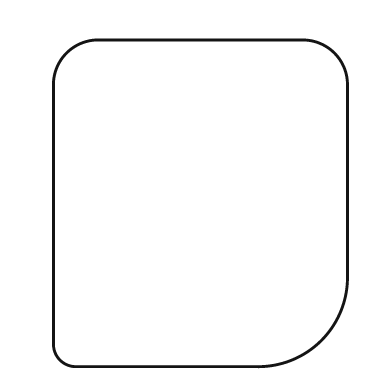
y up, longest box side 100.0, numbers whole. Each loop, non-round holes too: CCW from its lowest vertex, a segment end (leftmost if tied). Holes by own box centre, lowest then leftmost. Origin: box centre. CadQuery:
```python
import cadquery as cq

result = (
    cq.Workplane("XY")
    .moveTo(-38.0, -50.0)
    .lineTo(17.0, -50.0)
    .threePointArc((37.0, -42.0), (45.0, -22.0))
    .lineTo(45.0, 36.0)
    .threePointArc((41.0, 46.0), (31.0, 50.0))
    .lineTo(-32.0, 50.0)
    .threePointArc((-41.0, 46.0), (-45.0, 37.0))
    .lineTo(-45.0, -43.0)
    .threePointArc((-43.0, -48.0), (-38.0, -50.0))
    .close()
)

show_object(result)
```